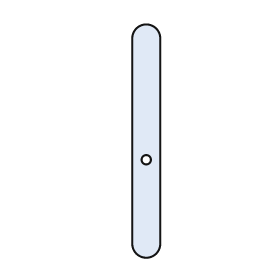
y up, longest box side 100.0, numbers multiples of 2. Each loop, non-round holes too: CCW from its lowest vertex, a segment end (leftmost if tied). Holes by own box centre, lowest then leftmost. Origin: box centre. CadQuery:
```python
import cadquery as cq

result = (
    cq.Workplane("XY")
    .moveTo(-6.0, -44.0)
    .threePointArc((0.0, -50.0), (6.0, -44.0))
    .lineTo(6.0, 44.0)
    .threePointArc((0.0, 50.0), (-6.0, 44.0))
    .close()
    .moveTo(0.0, -8.0)
    .circle(2.0)
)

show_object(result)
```